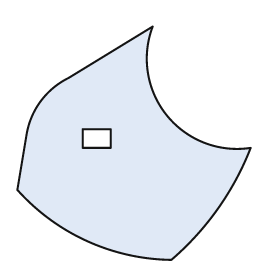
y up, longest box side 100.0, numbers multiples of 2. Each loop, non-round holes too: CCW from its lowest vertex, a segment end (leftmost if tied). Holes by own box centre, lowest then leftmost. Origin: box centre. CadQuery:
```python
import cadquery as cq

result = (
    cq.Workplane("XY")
    .moveTo(16.0, -50.0)
    .threePointArc((36.0, -28.0), (50.0, -2.0))
    .threePointArc((14.0, 12.0), (8.0, 50.0))
    .lineTo(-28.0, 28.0)
    .threePointArc((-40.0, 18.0), (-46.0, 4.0))
    .lineTo(-50.0, -20.0)
    .threePointArc((-20.0, -42.0), (16.0, -50.0))
    .close()
    .moveTo(-22.0, -2.0)
    .lineTo(-10.0, -2.0)
    .lineTo(-10.0, 6.0)
    .lineTo(-22.0, 6.0)
    .close()
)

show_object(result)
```